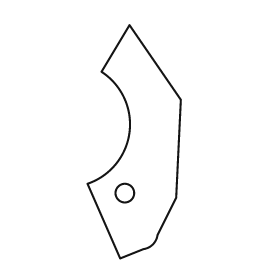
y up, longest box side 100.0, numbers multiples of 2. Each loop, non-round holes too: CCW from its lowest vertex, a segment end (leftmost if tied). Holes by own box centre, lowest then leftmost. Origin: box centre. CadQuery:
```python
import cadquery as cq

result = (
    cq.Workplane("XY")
    .moveTo(-6.0, -50.0)
    .lineTo(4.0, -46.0)
    .threePointArc((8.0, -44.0), (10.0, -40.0))
    .lineTo(18.0, -24.0)
    .lineTo(20.0, 18.0)
    .lineTo(-2.0, 50.0)
    .lineTo(-14.0, 30.0)
    .threePointArc((-2.0, 4.0), (-20.0, -18.0))
    .close()
    .moveTo(-4.0, -22.0)
    .circle(4.0)
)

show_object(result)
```